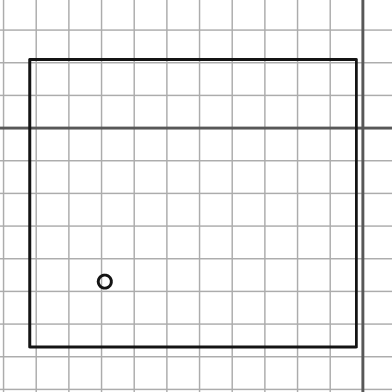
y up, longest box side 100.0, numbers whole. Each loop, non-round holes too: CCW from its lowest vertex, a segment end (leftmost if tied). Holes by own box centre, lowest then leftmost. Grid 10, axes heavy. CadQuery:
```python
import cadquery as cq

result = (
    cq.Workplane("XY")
    .moveTo(-102.0, -67.0)
    .lineTo(-2.0, -67.0)
    .lineTo(-2.0, 21.0)
    .lineTo(-102.0, 21.0)
    .close()
    .moveTo(-79.0, -47.0)
    .circle(2.0)
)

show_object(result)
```